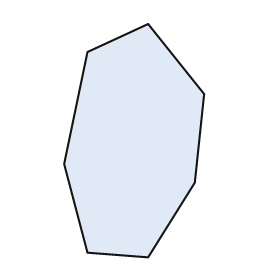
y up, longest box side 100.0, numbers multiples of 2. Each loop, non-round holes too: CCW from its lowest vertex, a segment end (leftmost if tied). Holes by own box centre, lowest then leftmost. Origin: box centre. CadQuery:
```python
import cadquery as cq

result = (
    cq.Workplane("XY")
    .moveTo(6.0, -50.0)
    .lineTo(26.0, -18.0)
    .lineTo(30.0, 20.0)
    .lineTo(6.0, 50.0)
    .lineTo(-20.0, 38.0)
    .lineTo(-30.0, -10.0)
    .lineTo(-20.0, -48.0)
    .close()
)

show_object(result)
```